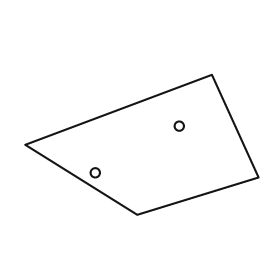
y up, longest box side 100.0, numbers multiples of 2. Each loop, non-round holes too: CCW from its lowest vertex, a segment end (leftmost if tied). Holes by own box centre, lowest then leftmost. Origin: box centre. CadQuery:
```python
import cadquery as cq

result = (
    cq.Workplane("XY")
    .moveTo(-2.0, -30.0)
    .lineTo(50.0, -14.0)
    .lineTo(30.0, 30.0)
    .lineTo(-50.0, 0.0)
    .close()
    .moveTo(-20.0, -12.0)
    .circle(2.0)
    .moveTo(16.0, 8.0)
    .circle(2.0)
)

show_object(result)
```